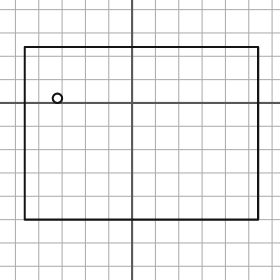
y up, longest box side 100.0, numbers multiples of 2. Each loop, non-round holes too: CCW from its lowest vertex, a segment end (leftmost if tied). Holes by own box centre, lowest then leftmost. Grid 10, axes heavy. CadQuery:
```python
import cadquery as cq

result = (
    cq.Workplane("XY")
    .moveTo(-46.0, -50.0)
    .lineTo(54.0, -50.0)
    .lineTo(54.0, 24.0)
    .lineTo(-46.0, 24.0)
    .close()
    .moveTo(-32.0, 2.0)
    .circle(2.0)
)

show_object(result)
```